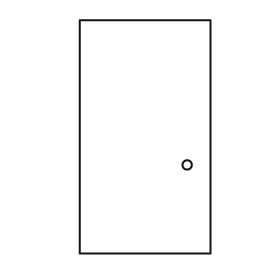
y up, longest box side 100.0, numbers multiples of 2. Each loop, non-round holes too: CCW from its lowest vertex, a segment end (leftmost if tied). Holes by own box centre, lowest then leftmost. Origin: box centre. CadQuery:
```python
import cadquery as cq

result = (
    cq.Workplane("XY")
    .moveTo(-28.0, -50.0)
    .lineTo(28.0, -50.0)
    .lineTo(28.0, 50.0)
    .lineTo(-28.0, 50.0)
    .close()
    .moveTo(18.0, -12.0)
    .circle(2.0)
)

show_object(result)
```